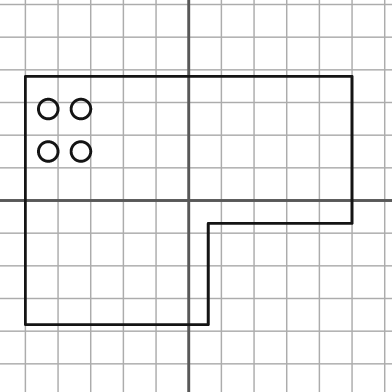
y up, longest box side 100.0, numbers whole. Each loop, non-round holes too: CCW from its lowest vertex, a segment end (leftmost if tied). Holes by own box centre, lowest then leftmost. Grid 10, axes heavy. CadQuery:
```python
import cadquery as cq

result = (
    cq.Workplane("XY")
    .moveTo(-50.0, -38.0)
    .lineTo(6.0, -38.0)
    .lineTo(6.0, -7.0)
    .lineTo(50.0, -7.0)
    .lineTo(50.0, 38.0)
    .lineTo(-50.0, 38.0)
    .close()
    .moveTo(-43.0, 15.0)
    .circle(3.0)
    .moveTo(-33.0, 15.0)
    .circle(3.0)
    .moveTo(-43.0, 28.0)
    .circle(3.0)
    .moveTo(-33.0, 28.0)
    .circle(3.0)
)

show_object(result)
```